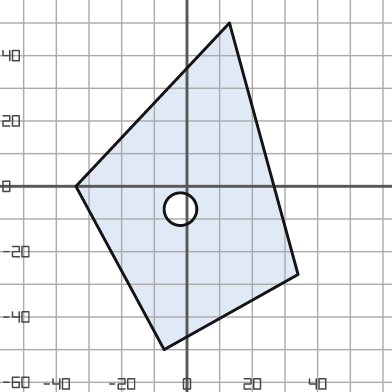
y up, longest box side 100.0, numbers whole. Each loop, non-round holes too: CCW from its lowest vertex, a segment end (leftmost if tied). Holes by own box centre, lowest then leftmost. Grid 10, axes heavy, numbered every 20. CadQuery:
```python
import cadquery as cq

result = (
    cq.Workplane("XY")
    .moveTo(-7.0, -50.0)
    .lineTo(34.0, -27.0)
    .lineTo(13.0, 50.0)
    .lineTo(-34.0, 0.0)
    .close()
    .moveTo(-2.0, -7.0)
    .circle(5.0)
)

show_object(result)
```